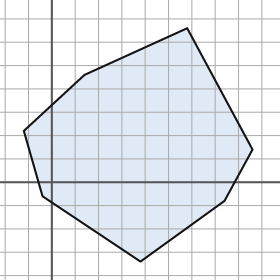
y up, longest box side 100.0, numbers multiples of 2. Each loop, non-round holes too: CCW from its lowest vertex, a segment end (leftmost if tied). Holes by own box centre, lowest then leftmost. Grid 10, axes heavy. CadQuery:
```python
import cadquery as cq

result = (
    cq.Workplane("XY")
    .moveTo(38.0, -34.0)
    .lineTo(74.0, -8.0)
    .lineTo(86.0, 14.0)
    .lineTo(58.0, 66.0)
    .lineTo(14.0, 46.0)
    .lineTo(-12.0, 22.0)
    .lineTo(-4.0, -6.0)
    .close()
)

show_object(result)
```